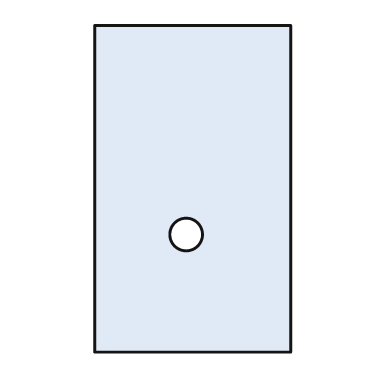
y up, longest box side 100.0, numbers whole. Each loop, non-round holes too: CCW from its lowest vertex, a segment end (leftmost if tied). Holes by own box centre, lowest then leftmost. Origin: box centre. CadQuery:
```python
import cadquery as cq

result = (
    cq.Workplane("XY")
    .moveTo(-30.0, -50.0)
    .lineTo(30.0, -50.0)
    .lineTo(30.0, 50.0)
    .lineTo(-30.0, 50.0)
    .close()
    .moveTo(-2.0, -14.0)
    .circle(5.0)
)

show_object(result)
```